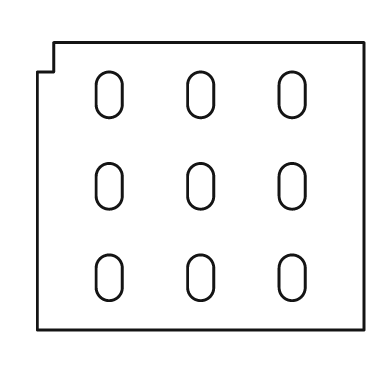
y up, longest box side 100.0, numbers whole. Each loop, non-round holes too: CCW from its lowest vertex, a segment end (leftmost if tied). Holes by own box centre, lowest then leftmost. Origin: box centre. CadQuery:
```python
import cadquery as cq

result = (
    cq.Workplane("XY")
    .moveTo(-50.0, -44.0)
    .lineTo(50.0, -44.0)
    .lineTo(50.0, 44.0)
    .lineTo(-45.0, 44.0)
    .lineTo(-45.0, 35.0)
    .lineTo(-50.0, 35.0)
    .close()
    .moveTo(-32.0, -31.0)
    .threePointArc((-28.0, -35.0), (-24.0, -31.0))
    .lineTo(-24.0, -25.0)
    .threePointArc((-28.0, -21.0), (-32.0, -25.0))
    .close()
    .moveTo(-4.0, -31.0)
    .threePointArc((0.0, -35.0), (4.0, -31.0))
    .lineTo(4.0, -25.0)
    .threePointArc((0.0, -21.0), (-4.0, -25.0))
    .close()
    .moveTo(24.0, -31.0)
    .threePointArc((28.0, -35.0), (32.0, -31.0))
    .lineTo(32.0, -25.0)
    .threePointArc((28.0, -21.0), (24.0, -25.0))
    .close()
    .moveTo(-32.0, -3.0)
    .threePointArc((-28.0, -7.0), (-24.0, -3.0))
    .lineTo(-24.0, 3.0)
    .threePointArc((-28.0, 7.0), (-32.0, 3.0))
    .close()
    .moveTo(-4.0, -3.0)
    .threePointArc((0.0, -7.0), (4.0, -3.0))
    .lineTo(4.0, 3.0)
    .threePointArc((0.0, 7.0), (-4.0, 3.0))
    .close()
    .moveTo(24.0, -3.0)
    .threePointArc((28.0, -7.0), (32.0, -3.0))
    .lineTo(32.0, 3.0)
    .threePointArc((28.0, 7.0), (24.0, 3.0))
    .close()
    .moveTo(-32.0, 25.0)
    .threePointArc((-28.0, 21.0), (-24.0, 25.0))
    .lineTo(-24.0, 31.0)
    .threePointArc((-28.0, 35.0), (-32.0, 31.0))
    .close()
    .moveTo(-4.0, 25.0)
    .threePointArc((0.0, 21.0), (4.0, 25.0))
    .lineTo(4.0, 31.0)
    .threePointArc((0.0, 35.0), (-4.0, 31.0))
    .close()
    .moveTo(24.0, 25.0)
    .threePointArc((28.0, 21.0), (32.0, 25.0))
    .lineTo(32.0, 31.0)
    .threePointArc((28.0, 35.0), (24.0, 31.0))
    .close()
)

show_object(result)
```